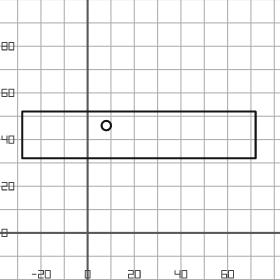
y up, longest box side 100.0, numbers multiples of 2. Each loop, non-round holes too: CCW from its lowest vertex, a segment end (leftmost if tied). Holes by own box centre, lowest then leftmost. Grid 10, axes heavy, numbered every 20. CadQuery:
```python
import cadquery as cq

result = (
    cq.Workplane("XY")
    .moveTo(-28.0, 32.0)
    .lineTo(72.0, 32.0)
    .lineTo(72.0, 52.0)
    .lineTo(-28.0, 52.0)
    .close()
    .moveTo(8.0, 46.0)
    .circle(2.0)
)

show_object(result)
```